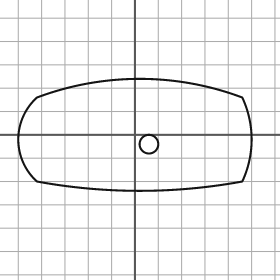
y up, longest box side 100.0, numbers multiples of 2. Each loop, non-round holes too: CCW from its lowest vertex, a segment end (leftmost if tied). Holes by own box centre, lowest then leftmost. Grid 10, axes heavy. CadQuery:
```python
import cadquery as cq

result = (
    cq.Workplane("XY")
    .moveTo(-42.0, -20.0)
    .threePointArc((2.0, -24.0), (46.0, -20.0))
    .threePointArc((50.0, -2.0), (46.0, 16.0))
    .threePointArc((2.0, 24.0), (-42.0, 16.0))
    .threePointArc((-50.0, -2.0), (-42.0, -20.0))
    .close()
    .moveTo(6.0, -4.0)
    .circle(4.0)
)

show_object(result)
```